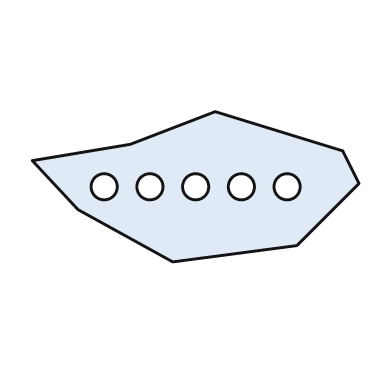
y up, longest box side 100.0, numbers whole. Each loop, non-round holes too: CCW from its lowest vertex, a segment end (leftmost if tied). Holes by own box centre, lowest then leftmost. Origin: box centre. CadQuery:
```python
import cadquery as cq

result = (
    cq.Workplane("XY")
    .moveTo(-7.0, -23.0)
    .lineTo(31.0, -18.0)
    .lineTo(50.0, 1.0)
    .lineTo(45.0, 11.0)
    .lineTo(6.0, 23.0)
    .lineTo(-20.0, 13.0)
    .lineTo(-50.0, 8.0)
    .lineTo(-36.0, -7.0)
    .close()
    .moveTo(-28.0, 0.0)
    .circle(4.0)
    .moveTo(-14.0, 0.0)
    .circle(4.0)
    .moveTo(0.0, 0.0)
    .circle(4.0)
    .moveTo(14.0, 0.0)
    .circle(4.0)
    .moveTo(28.0, 0.0)
    .circle(4.0)
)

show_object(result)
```